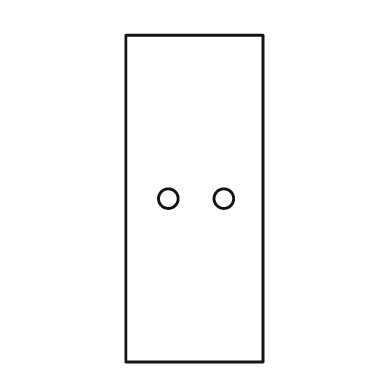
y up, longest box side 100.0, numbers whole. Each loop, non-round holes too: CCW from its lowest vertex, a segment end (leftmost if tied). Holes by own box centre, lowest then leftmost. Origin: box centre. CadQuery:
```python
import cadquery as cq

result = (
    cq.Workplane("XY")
    .moveTo(-21.0, -50.0)
    .lineTo(21.0, -50.0)
    .lineTo(21.0, 50.0)
    .lineTo(-21.0, 50.0)
    .close()
    .moveTo(-8.0, 0.0)
    .circle(3.0)
    .moveTo(9.0, 0.0)
    .circle(3.0)
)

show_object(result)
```